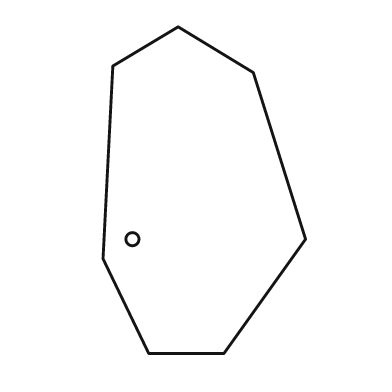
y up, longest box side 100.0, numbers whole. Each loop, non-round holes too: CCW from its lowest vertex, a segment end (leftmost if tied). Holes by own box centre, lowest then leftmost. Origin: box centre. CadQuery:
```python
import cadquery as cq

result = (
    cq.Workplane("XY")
    .moveTo(-17.0, -50.0)
    .lineTo(6.0, -50.0)
    .lineTo(31.0, -15.0)
    .lineTo(15.0, 36.0)
    .lineTo(-8.0, 50.0)
    .lineTo(-28.0, 38.0)
    .lineTo(-31.0, -21.0)
    .close()
    .moveTo(-22.0, -15.0)
    .circle(2.0)
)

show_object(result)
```